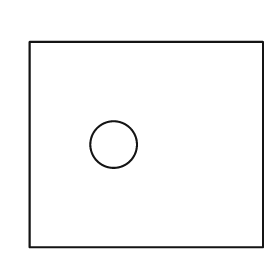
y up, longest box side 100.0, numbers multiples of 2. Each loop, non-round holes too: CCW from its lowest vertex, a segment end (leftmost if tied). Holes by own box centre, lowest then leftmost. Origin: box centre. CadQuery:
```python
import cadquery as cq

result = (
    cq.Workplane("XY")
    .moveTo(-50.0, -44.0)
    .lineTo(50.0, -44.0)
    .lineTo(50.0, 44.0)
    .lineTo(-50.0, 44.0)
    .close()
    .moveTo(-14.0, 0.0)
    .circle(10.0)
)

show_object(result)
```